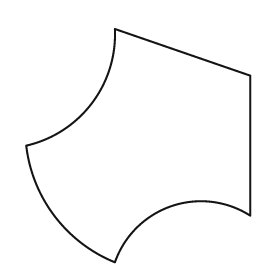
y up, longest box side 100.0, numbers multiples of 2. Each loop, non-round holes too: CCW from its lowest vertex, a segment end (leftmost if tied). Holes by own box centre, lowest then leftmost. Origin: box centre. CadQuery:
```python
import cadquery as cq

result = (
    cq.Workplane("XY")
    .moveTo(-10.0, -50.0)
    .threePointArc((14.0, -26.0), (48.0, -30.0))
    .lineTo(48.0, 30.0)
    .lineTo(-10.0, 50.0)
    .threePointArc((-20.0, 18.0), (-48.0, 0.0))
    .threePointArc((-36.0, -30.0), (-10.0, -50.0))
    .close()
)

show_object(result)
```